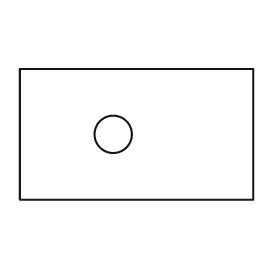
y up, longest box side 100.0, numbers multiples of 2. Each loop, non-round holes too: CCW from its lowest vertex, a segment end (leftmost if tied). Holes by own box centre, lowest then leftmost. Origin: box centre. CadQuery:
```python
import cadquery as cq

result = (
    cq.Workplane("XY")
    .moveTo(-50.0, -28.0)
    .lineTo(50.0, -28.0)
    .lineTo(50.0, 28.0)
    .lineTo(-50.0, 28.0)
    .close()
    .moveTo(-10.0, 0.0)
    .circle(8.0)
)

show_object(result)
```